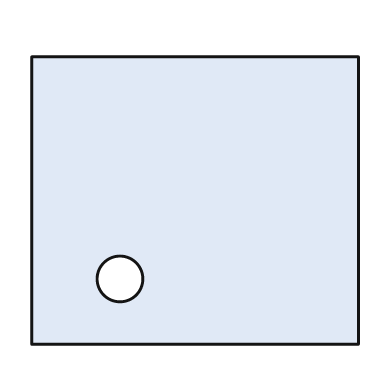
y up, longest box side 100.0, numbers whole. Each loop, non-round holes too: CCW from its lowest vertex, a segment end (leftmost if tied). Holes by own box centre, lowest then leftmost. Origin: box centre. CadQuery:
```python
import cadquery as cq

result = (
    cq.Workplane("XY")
    .moveTo(-50.0, -44.0)
    .lineTo(50.0, -44.0)
    .lineTo(50.0, 44.0)
    .lineTo(-50.0, 44.0)
    .close()
    .moveTo(-23.0, -24.0)
    .circle(7.0)
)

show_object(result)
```